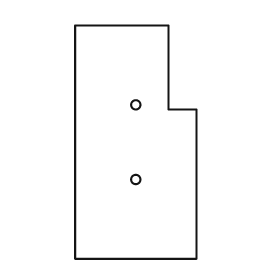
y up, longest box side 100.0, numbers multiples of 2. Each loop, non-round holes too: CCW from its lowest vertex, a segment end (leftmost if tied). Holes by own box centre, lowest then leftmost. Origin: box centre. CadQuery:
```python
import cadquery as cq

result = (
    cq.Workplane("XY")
    .moveTo(-26.0, -50.0)
    .lineTo(26.0, -50.0)
    .lineTo(26.0, 14.0)
    .lineTo(14.0, 14.0)
    .lineTo(14.0, 50.0)
    .lineTo(-26.0, 50.0)
    .close()
    .moveTo(0.0, -16.0)
    .circle(2.0)
    .moveTo(0.0, 16.0)
    .circle(2.0)
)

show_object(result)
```